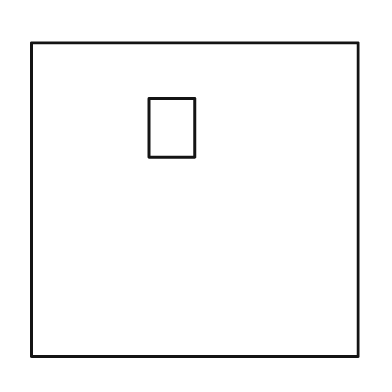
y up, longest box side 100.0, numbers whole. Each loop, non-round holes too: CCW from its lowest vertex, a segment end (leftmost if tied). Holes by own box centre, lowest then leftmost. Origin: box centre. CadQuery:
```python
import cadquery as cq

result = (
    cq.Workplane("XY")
    .moveTo(-50.0, -48.0)
    .lineTo(50.0, -48.0)
    .lineTo(50.0, 48.0)
    .lineTo(-50.0, 48.0)
    .close()
    .moveTo(-14.0, 13.0)
    .lineTo(0.0, 13.0)
    .lineTo(0.0, 31.0)
    .lineTo(-14.0, 31.0)
    .close()
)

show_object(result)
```